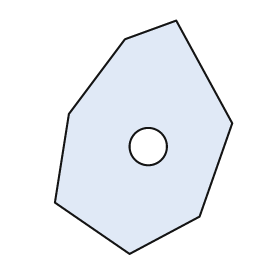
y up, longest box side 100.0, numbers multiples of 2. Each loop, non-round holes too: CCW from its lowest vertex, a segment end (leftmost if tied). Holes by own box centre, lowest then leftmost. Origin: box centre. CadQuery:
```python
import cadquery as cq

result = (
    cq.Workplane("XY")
    .moveTo(-6.0, -50.0)
    .lineTo(24.0, -34.0)
    .lineTo(38.0, 6.0)
    .lineTo(14.0, 50.0)
    .lineTo(-8.0, 42.0)
    .lineTo(-32.0, 10.0)
    .lineTo(-38.0, -28.0)
    .close()
    .moveTo(2.0, -4.0)
    .circle(8.0)
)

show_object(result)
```